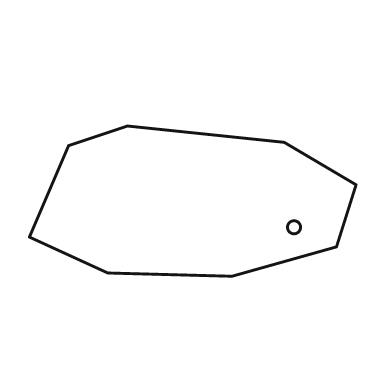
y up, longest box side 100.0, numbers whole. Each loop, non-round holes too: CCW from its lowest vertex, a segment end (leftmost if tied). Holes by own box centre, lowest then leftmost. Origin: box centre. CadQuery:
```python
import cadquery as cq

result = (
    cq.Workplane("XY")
    .moveTo(12.0, -23.0)
    .lineTo(44.0, -14.0)
    .lineTo(50.0, 5.0)
    .lineTo(28.0, 18.0)
    .lineTo(-20.0, 23.0)
    .lineTo(-38.0, 17.0)
    .lineTo(-50.0, -11.0)
    .lineTo(-26.0, -22.0)
    .close()
    .moveTo(31.0, -8.0)
    .circle(2.0)
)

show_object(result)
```